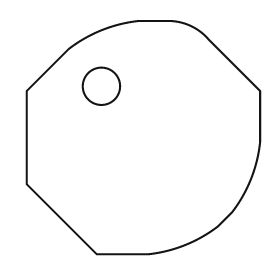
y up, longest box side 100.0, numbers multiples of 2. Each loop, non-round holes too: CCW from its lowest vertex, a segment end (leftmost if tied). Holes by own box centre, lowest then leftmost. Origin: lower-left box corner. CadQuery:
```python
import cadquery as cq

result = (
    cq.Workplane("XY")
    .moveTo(30.0, 0.0)
    .lineTo(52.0, 0.0)
    .threePointArc((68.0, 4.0), (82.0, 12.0))
    .lineTo(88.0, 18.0)
    .threePointArc((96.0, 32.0), (100.0, 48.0))
    .lineTo(100.0, 70.0)
    .lineTo(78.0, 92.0)
    .threePointArc((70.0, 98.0), (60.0, 100.0))
    .lineTo(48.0, 100.0)
    .threePointArc((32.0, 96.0), (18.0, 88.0))
    .lineTo(0.0, 70.0)
    .lineTo(0.0, 30.0)
    .close()
    .moveTo(32.0, 72.0)
    .circle(8.0)
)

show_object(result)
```